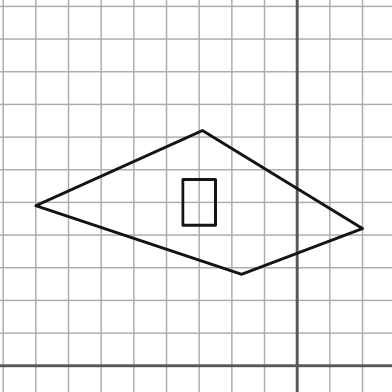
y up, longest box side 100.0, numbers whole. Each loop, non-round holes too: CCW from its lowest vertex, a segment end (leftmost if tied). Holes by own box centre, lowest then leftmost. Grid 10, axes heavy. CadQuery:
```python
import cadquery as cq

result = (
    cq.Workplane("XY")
    .moveTo(-17.0, 28.0)
    .lineTo(20.0, 42.0)
    .lineTo(-29.0, 72.0)
    .lineTo(-80.0, 49.0)
    .close()
    .moveTo(-35.0, 43.0)
    .lineTo(-25.0, 43.0)
    .lineTo(-25.0, 57.0)
    .lineTo(-35.0, 57.0)
    .close()
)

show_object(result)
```